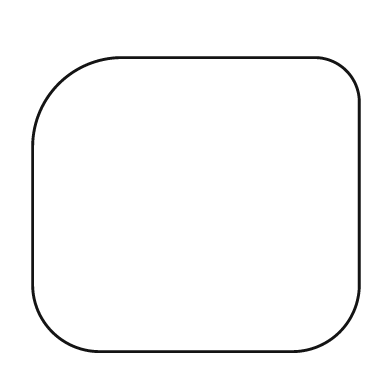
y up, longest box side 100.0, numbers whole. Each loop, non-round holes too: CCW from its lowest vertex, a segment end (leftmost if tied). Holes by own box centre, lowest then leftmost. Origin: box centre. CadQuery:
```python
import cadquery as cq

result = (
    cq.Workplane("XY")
    .moveTo(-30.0, -45.0)
    .lineTo(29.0, -45.0)
    .threePointArc((44.0, -39.0), (50.0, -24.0))
    .lineTo(50.0, 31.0)
    .threePointArc((46.0, 41.0), (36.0, 45.0))
    .lineTo(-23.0, 45.0)
    .threePointArc((-42.0, 37.0), (-50.0, 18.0))
    .lineTo(-50.0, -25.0)
    .threePointArc((-44.0, -39.0), (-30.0, -45.0))
    .close()
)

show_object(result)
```